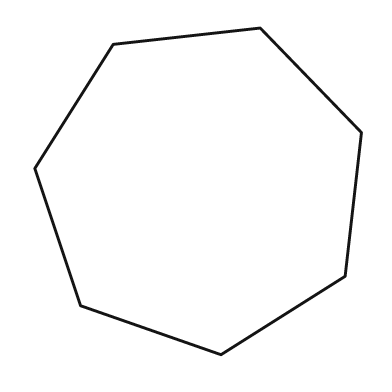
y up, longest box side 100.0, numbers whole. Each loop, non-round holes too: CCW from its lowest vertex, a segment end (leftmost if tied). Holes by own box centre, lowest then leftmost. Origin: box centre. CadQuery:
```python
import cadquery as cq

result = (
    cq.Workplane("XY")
    .moveTo(7.0, -50.0)
    .lineTo(45.0, -26.0)
    .lineTo(50.0, 18.0)
    .lineTo(19.0, 50.0)
    .lineTo(-26.0, 45.0)
    .lineTo(-50.0, 7.0)
    .lineTo(-36.0, -35.0)
    .close()
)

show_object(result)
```